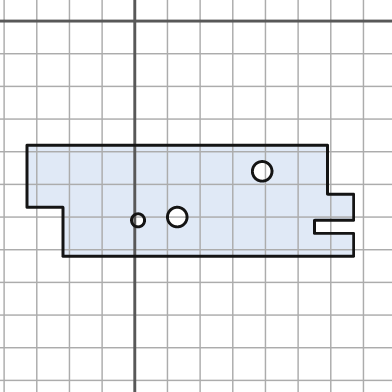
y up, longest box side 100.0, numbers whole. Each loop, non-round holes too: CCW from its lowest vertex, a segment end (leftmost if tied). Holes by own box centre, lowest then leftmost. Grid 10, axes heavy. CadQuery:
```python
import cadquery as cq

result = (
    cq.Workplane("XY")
    .moveTo(-22.0, -72.0)
    .lineTo(67.0, -72.0)
    .lineTo(67.0, -65.0)
    .lineTo(55.0, -65.0)
    .lineTo(55.0, -61.0)
    .lineTo(67.0, -61.0)
    .lineTo(67.0, -53.0)
    .lineTo(59.0, -53.0)
    .lineTo(59.0, -38.0)
    .lineTo(-33.0, -38.0)
    .lineTo(-33.0, -57.0)
    .lineTo(-22.0, -57.0)
    .close()
    .moveTo(1.0, -61.0)
    .circle(2.0)
    .moveTo(13.0, -60.0)
    .circle(3.0)
    .moveTo(39.0, -46.0)
    .circle(3.0)
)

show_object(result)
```